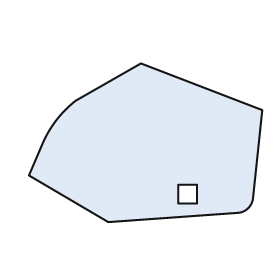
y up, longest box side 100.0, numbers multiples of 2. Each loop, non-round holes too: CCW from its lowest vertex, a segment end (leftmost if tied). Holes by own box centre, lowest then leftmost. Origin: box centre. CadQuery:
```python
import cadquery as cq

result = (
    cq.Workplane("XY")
    .moveTo(-16.0, -34.0)
    .lineTo(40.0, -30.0)
    .threePointArc((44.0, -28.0), (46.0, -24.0))
    .lineTo(50.0, 14.0)
    .lineTo(-2.0, 34.0)
    .lineTo(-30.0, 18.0)
    .threePointArc((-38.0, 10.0), (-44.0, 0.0))
    .lineTo(-50.0, -14.0)
    .close()
    .moveTo(14.0, -26.0)
    .lineTo(22.0, -26.0)
    .lineTo(22.0, -18.0)
    .lineTo(14.0, -18.0)
    .close()
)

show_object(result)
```